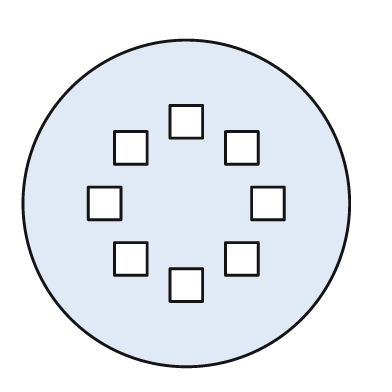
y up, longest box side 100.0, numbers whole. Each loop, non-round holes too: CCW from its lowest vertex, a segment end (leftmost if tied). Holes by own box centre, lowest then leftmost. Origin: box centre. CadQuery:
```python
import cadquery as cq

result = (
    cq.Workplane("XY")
    .moveTo(0.0, 0.0)
    .circle(50.0)
    .moveTo(-5.0, -30.0)
    .lineTo(5.0, -30.0)
    .lineTo(5.0, -20.0)
    .lineTo(-5.0, -20.0)
    .close()
    .moveTo(-22.0, -22.0)
    .lineTo(-12.0, -22.0)
    .lineTo(-12.0, -12.0)
    .lineTo(-22.0, -12.0)
    .close()
    .moveTo(12.0, -22.0)
    .lineTo(22.0, -22.0)
    .lineTo(22.0, -12.0)
    .lineTo(12.0, -12.0)
    .close()
    .moveTo(-30.0, -5.0)
    .lineTo(-20.0, -5.0)
    .lineTo(-20.0, 5.0)
    .lineTo(-30.0, 5.0)
    .close()
    .moveTo(20.0, -5.0)
    .lineTo(30.0, -5.0)
    .lineTo(30.0, 5.0)
    .lineTo(20.0, 5.0)
    .close()
    .moveTo(-22.0, 12.0)
    .lineTo(-12.0, 12.0)
    .lineTo(-12.0, 22.0)
    .lineTo(-22.0, 22.0)
    .close()
    .moveTo(12.0, 12.0)
    .lineTo(22.0, 12.0)
    .lineTo(22.0, 22.0)
    .lineTo(12.0, 22.0)
    .close()
    .moveTo(-5.0, 20.0)
    .lineTo(5.0, 20.0)
    .lineTo(5.0, 30.0)
    .lineTo(-5.0, 30.0)
    .close()
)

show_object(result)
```